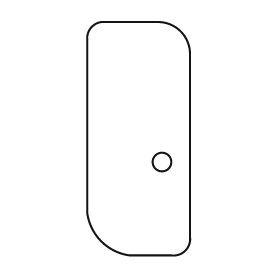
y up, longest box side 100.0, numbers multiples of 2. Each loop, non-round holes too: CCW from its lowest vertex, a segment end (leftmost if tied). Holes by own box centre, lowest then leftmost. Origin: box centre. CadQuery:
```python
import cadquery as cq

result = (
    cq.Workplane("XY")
    .moveTo(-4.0, -50.0)
    .lineTo(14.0, -50.0)
    .threePointArc((20.0, -48.0), (22.0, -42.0))
    .lineTo(22.0, 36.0)
    .threePointArc((18.0, 46.0), (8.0, 50.0))
    .lineTo(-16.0, 50.0)
    .threePointArc((-20.0, 48.0), (-22.0, 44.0))
    .lineTo(-22.0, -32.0)
    .threePointArc((-16.0, -44.0), (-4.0, -50.0))
    .close()
    .moveTo(10.0, -10.0)
    .circle(4.0)
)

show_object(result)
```